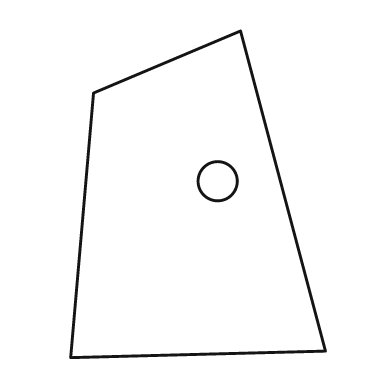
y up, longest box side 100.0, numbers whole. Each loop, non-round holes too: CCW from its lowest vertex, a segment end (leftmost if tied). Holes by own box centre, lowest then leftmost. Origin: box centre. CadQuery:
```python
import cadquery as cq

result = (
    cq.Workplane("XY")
    .moveTo(-39.0, -50.0)
    .lineTo(39.0, -48.0)
    .lineTo(13.0, 50.0)
    .lineTo(-32.0, 31.0)
    .close()
    .moveTo(6.0, 4.0)
    .circle(6.0)
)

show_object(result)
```